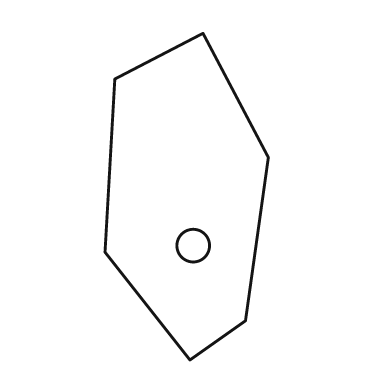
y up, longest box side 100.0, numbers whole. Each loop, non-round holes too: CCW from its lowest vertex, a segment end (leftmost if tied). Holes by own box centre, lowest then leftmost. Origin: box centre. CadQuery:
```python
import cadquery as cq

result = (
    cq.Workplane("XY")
    .moveTo(1.0, -50.0)
    .lineTo(18.0, -38.0)
    .lineTo(25.0, 12.0)
    .lineTo(5.0, 50.0)
    .lineTo(-22.0, 36.0)
    .lineTo(-25.0, -17.0)
    .close()
    .moveTo(2.0, -15.0)
    .circle(5.0)
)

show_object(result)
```